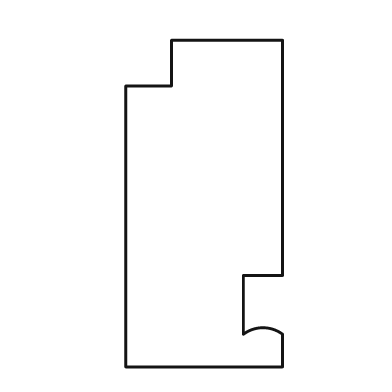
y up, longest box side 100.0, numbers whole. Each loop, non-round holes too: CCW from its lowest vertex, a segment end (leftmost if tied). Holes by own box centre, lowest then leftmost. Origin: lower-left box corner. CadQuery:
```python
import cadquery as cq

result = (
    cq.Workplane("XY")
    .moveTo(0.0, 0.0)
    .lineTo(48.0, 0.0)
    .lineTo(48.0, 10.0)
    .threePointArc((42.0, 12.0), (36.0, 10.0))
    .lineTo(36.0, 28.0)
    .lineTo(48.0, 28.0)
    .lineTo(48.0, 100.0)
    .lineTo(14.0, 100.0)
    .lineTo(14.0, 86.0)
    .lineTo(0.0, 86.0)
    .close()
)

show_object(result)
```